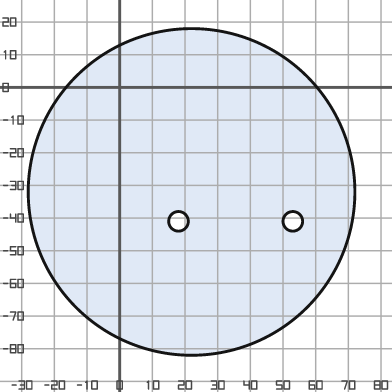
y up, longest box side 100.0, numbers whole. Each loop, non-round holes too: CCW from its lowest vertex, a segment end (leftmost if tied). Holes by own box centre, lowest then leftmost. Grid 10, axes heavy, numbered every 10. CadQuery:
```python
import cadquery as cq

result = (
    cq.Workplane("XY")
    .moveTo(22.0, -32.0)
    .circle(50.0)
    .moveTo(18.0, -41.0)
    .circle(3.0)
    .moveTo(53.0, -41.0)
    .circle(3.0)
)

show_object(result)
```